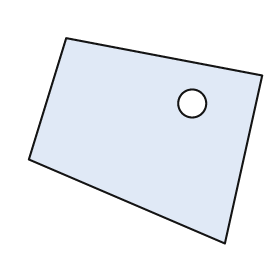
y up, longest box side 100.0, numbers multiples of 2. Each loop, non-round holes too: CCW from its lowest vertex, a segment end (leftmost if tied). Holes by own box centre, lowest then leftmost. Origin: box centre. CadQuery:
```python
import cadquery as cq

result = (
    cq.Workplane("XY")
    .moveTo(34.0, -44.0)
    .lineTo(50.0, 28.0)
    .lineTo(-34.0, 44.0)
    .lineTo(-50.0, -8.0)
    .close()
    .moveTo(20.0, 16.0)
    .circle(6.0)
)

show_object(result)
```